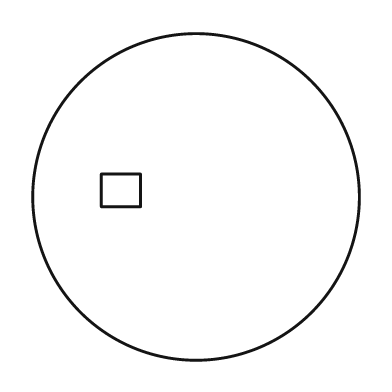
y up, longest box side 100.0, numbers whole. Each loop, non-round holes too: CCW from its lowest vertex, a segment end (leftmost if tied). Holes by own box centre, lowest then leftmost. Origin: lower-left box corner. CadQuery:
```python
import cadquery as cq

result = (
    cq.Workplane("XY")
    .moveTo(50.0, 50.0)
    .circle(50.0)
    .moveTo(21.0, 47.0)
    .lineTo(33.0, 47.0)
    .lineTo(33.0, 57.0)
    .lineTo(21.0, 57.0)
    .close()
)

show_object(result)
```